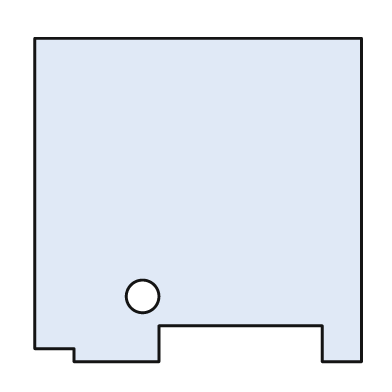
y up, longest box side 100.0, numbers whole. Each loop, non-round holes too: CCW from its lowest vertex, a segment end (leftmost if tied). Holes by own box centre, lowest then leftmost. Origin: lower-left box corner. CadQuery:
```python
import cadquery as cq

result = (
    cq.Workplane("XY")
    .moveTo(12.0, 0.0)
    .lineTo(38.0, 0.0)
    .lineTo(38.0, 11.0)
    .lineTo(88.0, 11.0)
    .lineTo(88.0, 0.0)
    .lineTo(100.0, 0.0)
    .lineTo(100.0, 99.0)
    .lineTo(0.0, 99.0)
    .lineTo(0.0, 4.0)
    .lineTo(12.0, 4.0)
    .close()
    .moveTo(33.0, 20.0)
    .circle(5.0)
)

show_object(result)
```